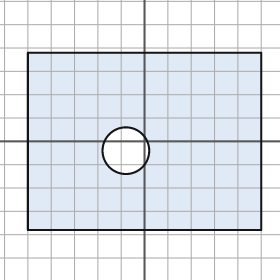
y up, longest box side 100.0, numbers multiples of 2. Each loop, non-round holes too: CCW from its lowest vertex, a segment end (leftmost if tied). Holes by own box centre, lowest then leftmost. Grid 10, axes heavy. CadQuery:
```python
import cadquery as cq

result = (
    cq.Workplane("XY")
    .moveTo(-50.0, -38.0)
    .lineTo(50.0, -38.0)
    .lineTo(50.0, 38.0)
    .lineTo(-50.0, 38.0)
    .close()
    .moveTo(-8.0, -4.0)
    .circle(10.0)
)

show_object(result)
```